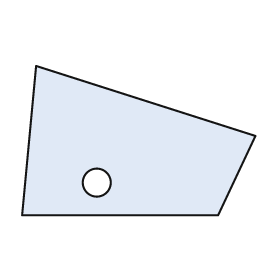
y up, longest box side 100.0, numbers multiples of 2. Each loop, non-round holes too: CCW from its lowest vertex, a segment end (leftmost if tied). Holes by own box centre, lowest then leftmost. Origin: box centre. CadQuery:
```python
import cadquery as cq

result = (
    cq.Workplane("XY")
    .moveTo(-50.0, -32.0)
    .lineTo(34.0, -32.0)
    .lineTo(50.0, 2.0)
    .lineTo(-44.0, 32.0)
    .close()
    .moveTo(-18.0, -18.0)
    .circle(6.0)
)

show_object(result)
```